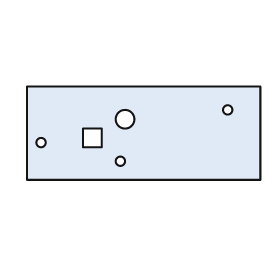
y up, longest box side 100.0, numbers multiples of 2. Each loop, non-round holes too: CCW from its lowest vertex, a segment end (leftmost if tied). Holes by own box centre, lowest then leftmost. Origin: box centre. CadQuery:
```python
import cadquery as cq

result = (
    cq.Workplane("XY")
    .moveTo(-50.0, -20.0)
    .lineTo(50.0, -20.0)
    .lineTo(50.0, 20.0)
    .lineTo(-50.0, 20.0)
    .close()
    .moveTo(-10.0, -12.0)
    .circle(2.0)
    .moveTo(-44.0, -4.0)
    .circle(2.0)
    .moveTo(-26.0, -6.0)
    .lineTo(-18.0, -6.0)
    .lineTo(-18.0, 2.0)
    .lineTo(-26.0, 2.0)
    .close()
    .moveTo(-8.0, 6.0)
    .circle(4.0)
    .moveTo(36.0, 10.0)
    .circle(2.0)
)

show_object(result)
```